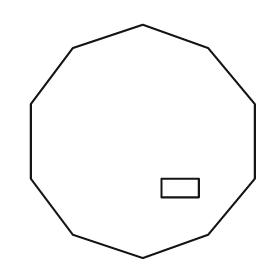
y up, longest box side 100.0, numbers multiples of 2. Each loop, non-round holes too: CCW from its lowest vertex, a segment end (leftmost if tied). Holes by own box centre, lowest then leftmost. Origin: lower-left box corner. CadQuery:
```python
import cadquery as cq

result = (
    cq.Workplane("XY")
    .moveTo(48.0, 0.0)
    .lineTo(76.0, 10.0)
    .lineTo(96.0, 34.0)
    .lineTo(96.0, 66.0)
    .lineTo(76.0, 90.0)
    .lineTo(48.0, 100.0)
    .lineTo(18.0, 90.0)
    .lineTo(0.0, 66.0)
    .lineTo(0.0, 34.0)
    .lineTo(18.0, 10.0)
    .close()
    .moveTo(56.0, 26.0)
    .lineTo(72.0, 26.0)
    .lineTo(72.0, 34.0)
    .lineTo(56.0, 34.0)
    .close()
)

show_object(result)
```